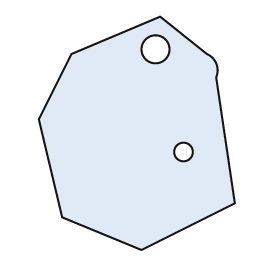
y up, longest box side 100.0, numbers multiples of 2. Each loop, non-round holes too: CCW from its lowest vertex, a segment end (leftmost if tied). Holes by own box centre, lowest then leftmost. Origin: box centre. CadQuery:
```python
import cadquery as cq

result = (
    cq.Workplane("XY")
    .moveTo(2.0, -50.0)
    .lineTo(42.0, -30.0)
    .lineTo(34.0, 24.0)
    .threePointArc((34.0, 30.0), (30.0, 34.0))
    .lineTo(10.0, 50.0)
    .lineTo(-28.0, 34.0)
    .lineTo(-42.0, 6.0)
    .lineTo(-32.0, -36.0)
    .close()
    .moveTo(20.0, -8.0)
    .circle(4.0)
    .moveTo(8.0, 36.0)
    .circle(6.0)
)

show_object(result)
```